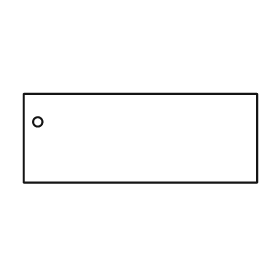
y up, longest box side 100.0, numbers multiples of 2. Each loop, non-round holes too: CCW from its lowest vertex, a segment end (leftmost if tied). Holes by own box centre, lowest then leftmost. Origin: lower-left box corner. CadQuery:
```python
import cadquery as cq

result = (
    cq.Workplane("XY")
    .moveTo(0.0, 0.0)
    .lineTo(100.0, 0.0)
    .lineTo(100.0, 38.0)
    .lineTo(0.0, 38.0)
    .close()
    .moveTo(6.0, 26.0)
    .circle(2.0)
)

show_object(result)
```